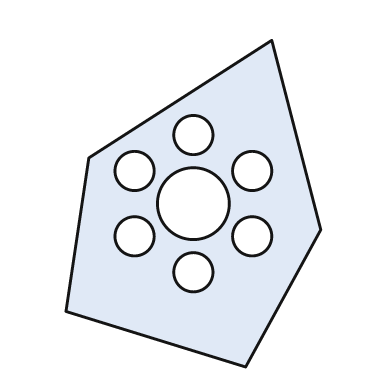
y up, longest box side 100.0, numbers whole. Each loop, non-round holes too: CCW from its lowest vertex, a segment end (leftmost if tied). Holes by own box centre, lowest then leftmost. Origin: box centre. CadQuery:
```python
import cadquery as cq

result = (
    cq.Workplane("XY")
    .moveTo(16.0, -50.0)
    .lineTo(39.0, -8.0)
    .lineTo(24.0, 50.0)
    .lineTo(-32.0, 14.0)
    .lineTo(-39.0, -33.0)
    .close()
    .moveTo(0.0, -21.0)
    .circle(6.0)
    .moveTo(-18.0, -10.0)
    .circle(6.0)
    .moveTo(18.0, -10.0)
    .circle(6.0)
    .moveTo(0.0, 0.0)
    .circle(11.0)
    .moveTo(-18.0, 10.0)
    .circle(6.0)
    .moveTo(18.0, 10.0)
    .circle(6.0)
    .moveTo(0.0, 21.0)
    .circle(6.0)
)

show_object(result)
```